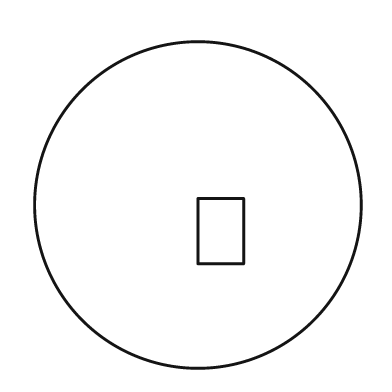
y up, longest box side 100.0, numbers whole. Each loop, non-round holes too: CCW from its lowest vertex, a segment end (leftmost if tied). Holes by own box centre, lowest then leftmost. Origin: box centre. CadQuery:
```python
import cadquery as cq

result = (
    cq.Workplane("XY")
    .moveTo(0.0, 0.0)
    .circle(50.0)
    .moveTo(0.0, -18.0)
    .lineTo(14.0, -18.0)
    .lineTo(14.0, 2.0)
    .lineTo(0.0, 2.0)
    .close()
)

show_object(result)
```